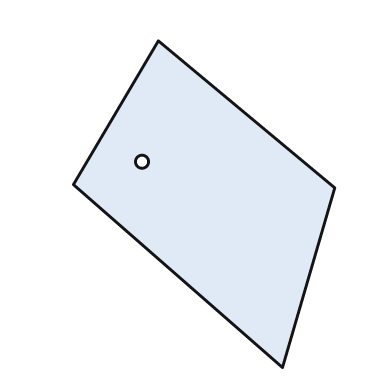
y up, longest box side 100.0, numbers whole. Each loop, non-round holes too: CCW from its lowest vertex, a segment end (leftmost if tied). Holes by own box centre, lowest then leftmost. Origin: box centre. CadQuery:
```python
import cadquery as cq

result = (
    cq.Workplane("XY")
    .moveTo(24.0, -50.0)
    .lineTo(40.0, 5.0)
    .lineTo(-14.0, 50.0)
    .lineTo(-40.0, 6.0)
    .close()
    .moveTo(-19.0, 13.0)
    .circle(2.0)
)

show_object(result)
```